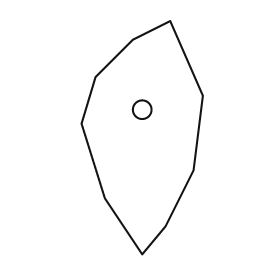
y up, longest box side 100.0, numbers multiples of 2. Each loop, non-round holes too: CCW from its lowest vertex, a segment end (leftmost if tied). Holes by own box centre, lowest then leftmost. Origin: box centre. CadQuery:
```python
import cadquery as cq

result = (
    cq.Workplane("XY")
    .moveTo(0.0, -50.0)
    .lineTo(10.0, -38.0)
    .lineTo(22.0, -14.0)
    .lineTo(26.0, 18.0)
    .lineTo(12.0, 50.0)
    .lineTo(-4.0, 42.0)
    .lineTo(-20.0, 26.0)
    .lineTo(-26.0, 6.0)
    .lineTo(-16.0, -26.0)
    .close()
    .moveTo(0.0, 12.0)
    .circle(4.0)
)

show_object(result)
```